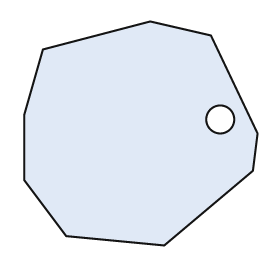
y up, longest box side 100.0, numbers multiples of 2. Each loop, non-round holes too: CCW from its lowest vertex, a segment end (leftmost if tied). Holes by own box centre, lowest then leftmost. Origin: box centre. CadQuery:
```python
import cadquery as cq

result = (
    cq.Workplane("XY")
    .moveTo(10.0, -48.0)
    .lineTo(48.0, -16.0)
    .lineTo(50.0, 0.0)
    .lineTo(30.0, 42.0)
    .lineTo(4.0, 48.0)
    .lineTo(-42.0, 36.0)
    .lineTo(-50.0, 8.0)
    .lineTo(-50.0, -20.0)
    .lineTo(-32.0, -44.0)
    .close()
    .moveTo(34.0, 6.0)
    .circle(6.0)
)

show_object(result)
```